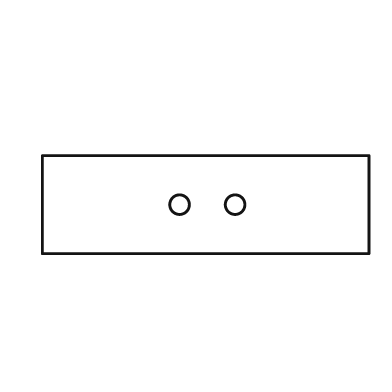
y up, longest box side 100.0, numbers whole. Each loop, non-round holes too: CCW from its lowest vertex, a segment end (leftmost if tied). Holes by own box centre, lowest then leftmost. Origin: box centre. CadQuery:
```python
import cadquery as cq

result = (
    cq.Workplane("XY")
    .moveTo(-50.0, -15.0)
    .lineTo(50.0, -15.0)
    .lineTo(50.0, 15.0)
    .lineTo(-50.0, 15.0)
    .close()
    .moveTo(-8.0, 0.0)
    .circle(3.0)
    .moveTo(9.0, 0.0)
    .circle(3.0)
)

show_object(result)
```